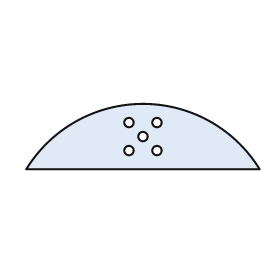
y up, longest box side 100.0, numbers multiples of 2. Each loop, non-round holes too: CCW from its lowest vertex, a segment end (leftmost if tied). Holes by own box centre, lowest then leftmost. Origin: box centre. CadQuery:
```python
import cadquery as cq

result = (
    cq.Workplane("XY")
    .moveTo(-50.0, -14.0)
    .lineTo(50.0, -14.0)
    .threePointArc((0.0, 14.0), (-50.0, -14.0))
    .close()
    .moveTo(-6.0, -6.0)
    .circle(2.0)
    .moveTo(6.0, -6.0)
    .circle(2.0)
    .moveTo(0.0, 0.0)
    .circle(2.0)
    .moveTo(-6.0, 6.0)
    .circle(2.0)
    .moveTo(6.0, 6.0)
    .circle(2.0)
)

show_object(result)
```